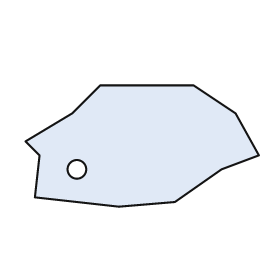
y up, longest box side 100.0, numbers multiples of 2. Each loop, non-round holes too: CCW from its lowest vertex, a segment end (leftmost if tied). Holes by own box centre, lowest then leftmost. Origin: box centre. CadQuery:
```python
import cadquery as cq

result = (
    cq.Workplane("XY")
    .moveTo(-10.0, -26.0)
    .lineTo(14.0, -24.0)
    .lineTo(34.0, -10.0)
    .lineTo(50.0, -4.0)
    .lineTo(40.0, 14.0)
    .lineTo(22.0, 26.0)
    .lineTo(-18.0, 26.0)
    .lineTo(-30.0, 14.0)
    .lineTo(-50.0, 2.0)
    .lineTo(-44.0, -4.0)
    .lineTo(-46.0, -22.0)
    .close()
    .moveTo(-28.0, -10.0)
    .circle(4.0)
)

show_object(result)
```